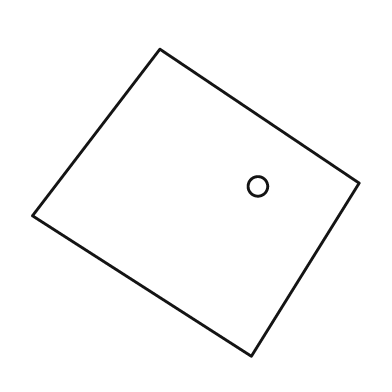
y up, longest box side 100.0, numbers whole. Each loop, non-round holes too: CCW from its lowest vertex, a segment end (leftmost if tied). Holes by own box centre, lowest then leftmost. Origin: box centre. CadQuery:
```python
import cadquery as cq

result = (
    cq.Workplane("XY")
    .moveTo(17.0, -47.0)
    .lineTo(50.0, 6.0)
    .lineTo(-11.0, 47.0)
    .lineTo(-50.0, -4.0)
    .close()
    .moveTo(19.0, 5.0)
    .circle(3.0)
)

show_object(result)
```